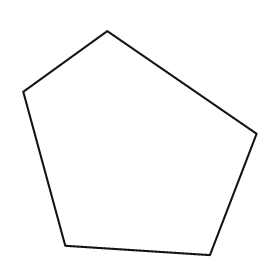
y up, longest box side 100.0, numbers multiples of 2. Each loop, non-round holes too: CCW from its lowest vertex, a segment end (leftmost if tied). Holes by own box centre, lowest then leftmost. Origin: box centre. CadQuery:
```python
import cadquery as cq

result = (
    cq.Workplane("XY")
    .moveTo(30.0, -48.0)
    .lineTo(50.0, 4.0)
    .lineTo(-14.0, 48.0)
    .lineTo(-50.0, 22.0)
    .lineTo(-32.0, -44.0)
    .close()
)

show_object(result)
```